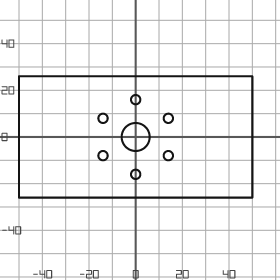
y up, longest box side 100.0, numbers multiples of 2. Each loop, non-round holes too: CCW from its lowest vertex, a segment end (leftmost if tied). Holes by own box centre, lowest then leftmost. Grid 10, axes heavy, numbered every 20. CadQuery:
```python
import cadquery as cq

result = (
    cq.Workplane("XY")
    .moveTo(-50.0, -26.0)
    .lineTo(50.0, -26.0)
    .lineTo(50.0, 26.0)
    .lineTo(-50.0, 26.0)
    .close()
    .moveTo(0.0, -16.0)
    .circle(2.0)
    .moveTo(-14.0, -8.0)
    .circle(2.0)
    .moveTo(14.0, -8.0)
    .circle(2.0)
    .moveTo(0.0, 0.0)
    .circle(6.0)
    .moveTo(-14.0, 8.0)
    .circle(2.0)
    .moveTo(14.0, 8.0)
    .circle(2.0)
    .moveTo(0.0, 16.0)
    .circle(2.0)
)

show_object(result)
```